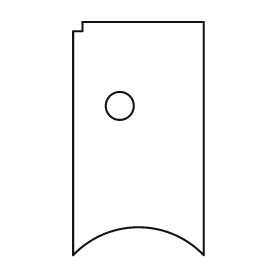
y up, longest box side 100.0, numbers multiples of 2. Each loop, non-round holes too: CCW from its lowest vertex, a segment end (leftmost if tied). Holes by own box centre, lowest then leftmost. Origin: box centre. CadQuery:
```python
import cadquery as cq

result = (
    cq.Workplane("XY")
    .moveTo(-28.0, -50.0)
    .threePointArc((0.0, -38.0), (28.0, -50.0))
    .lineTo(28.0, 50.0)
    .lineTo(-24.0, 50.0)
    .lineTo(-24.0, 46.0)
    .lineTo(-28.0, 46.0)
    .close()
    .moveTo(-8.0, 14.0)
    .circle(6.0)
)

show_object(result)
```